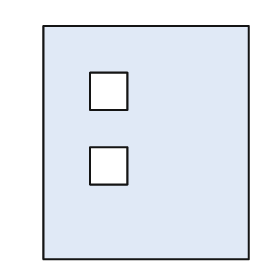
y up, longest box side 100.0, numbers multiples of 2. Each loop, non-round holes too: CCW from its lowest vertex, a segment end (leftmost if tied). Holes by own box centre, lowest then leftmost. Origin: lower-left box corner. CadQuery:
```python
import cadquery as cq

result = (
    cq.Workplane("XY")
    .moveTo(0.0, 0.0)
    .lineTo(88.0, 0.0)
    .lineTo(88.0, 100.0)
    .lineTo(0.0, 100.0)
    .close()
    .moveTo(20.0, 32.0)
    .lineTo(36.0, 32.0)
    .lineTo(36.0, 48.0)
    .lineTo(20.0, 48.0)
    .close()
    .moveTo(20.0, 64.0)
    .lineTo(36.0, 64.0)
    .lineTo(36.0, 80.0)
    .lineTo(20.0, 80.0)
    .close()
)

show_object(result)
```